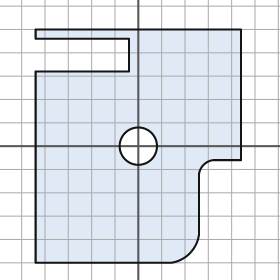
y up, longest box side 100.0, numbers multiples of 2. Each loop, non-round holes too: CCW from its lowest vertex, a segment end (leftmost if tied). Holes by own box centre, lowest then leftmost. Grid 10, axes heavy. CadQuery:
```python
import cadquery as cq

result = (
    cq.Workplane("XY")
    .moveTo(-44.0, -50.0)
    .lineTo(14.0, -50.0)
    .threePointArc((22.0, -46.0), (26.0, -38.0))
    .lineTo(26.0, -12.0)
    .threePointArc((28.0, -8.0), (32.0, -6.0))
    .lineTo(44.0, -6.0)
    .lineTo(44.0, 50.0)
    .lineTo(-44.0, 50.0)
    .lineTo(-44.0, 46.0)
    .lineTo(-4.0, 46.0)
    .lineTo(-4.0, 32.0)
    .lineTo(-44.0, 32.0)
    .close()
    .moveTo(0.0, 0.0)
    .circle(8.0)
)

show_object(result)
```